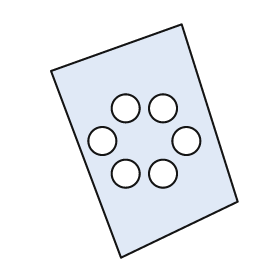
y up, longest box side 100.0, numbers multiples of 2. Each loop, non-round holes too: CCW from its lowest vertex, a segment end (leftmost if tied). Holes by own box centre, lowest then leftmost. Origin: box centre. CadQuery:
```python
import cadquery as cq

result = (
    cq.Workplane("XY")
    .moveTo(-10.0, -50.0)
    .lineTo(40.0, -26.0)
    .lineTo(16.0, 50.0)
    .lineTo(-40.0, 30.0)
    .close()
    .moveTo(-8.0, -14.0)
    .circle(6.0)
    .moveTo(8.0, -14.0)
    .circle(6.0)
    .moveTo(-18.0, 0.0)
    .circle(6.0)
    .moveTo(18.0, 0.0)
    .circle(6.0)
    .moveTo(-8.0, 14.0)
    .circle(6.0)
    .moveTo(8.0, 14.0)
    .circle(6.0)
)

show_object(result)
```